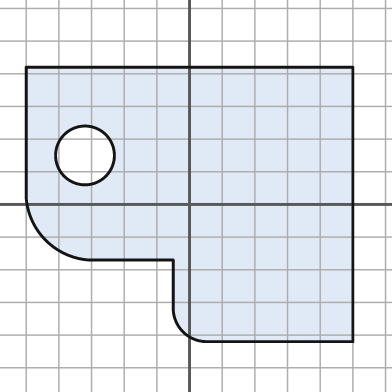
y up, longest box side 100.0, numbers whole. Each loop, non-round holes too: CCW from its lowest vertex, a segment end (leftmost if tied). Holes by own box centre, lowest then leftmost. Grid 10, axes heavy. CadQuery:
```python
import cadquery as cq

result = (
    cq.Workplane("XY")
    .moveTo(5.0, -42.0)
    .lineTo(50.0, -42.0)
    .lineTo(50.0, 42.0)
    .lineTo(-50.0, 42.0)
    .lineTo(-50.0, 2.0)
    .threePointArc((-44.0, -11.0), (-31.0, -17.0))
    .lineTo(-5.0, -17.0)
    .lineTo(-5.0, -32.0)
    .threePointArc((-2.0, -39.0), (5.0, -42.0))
    .close()
    .moveTo(-32.0, 15.0)
    .circle(9.0)
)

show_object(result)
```